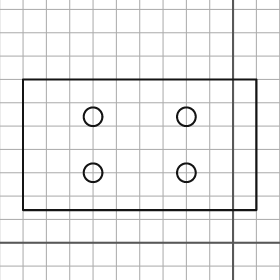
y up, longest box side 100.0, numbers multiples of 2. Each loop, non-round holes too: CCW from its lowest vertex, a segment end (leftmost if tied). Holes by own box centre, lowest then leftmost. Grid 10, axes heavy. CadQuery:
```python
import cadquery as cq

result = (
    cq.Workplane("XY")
    .moveTo(-90.0, 14.0)
    .lineTo(10.0, 14.0)
    .lineTo(10.0, 70.0)
    .lineTo(-90.0, 70.0)
    .close()
    .moveTo(-60.0, 30.0)
    .circle(4.0)
    .moveTo(-20.0, 30.0)
    .circle(4.0)
    .moveTo(-60.0, 54.0)
    .circle(4.0)
    .moveTo(-20.0, 54.0)
    .circle(4.0)
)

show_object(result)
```